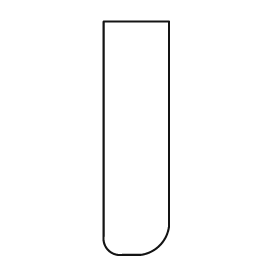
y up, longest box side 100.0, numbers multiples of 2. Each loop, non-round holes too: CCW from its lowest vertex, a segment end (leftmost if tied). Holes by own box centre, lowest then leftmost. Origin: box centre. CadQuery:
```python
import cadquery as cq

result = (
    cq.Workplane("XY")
    .moveTo(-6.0, -50.0)
    .lineTo(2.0, -50.0)
    .threePointArc((10.0, -46.0), (14.0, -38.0))
    .lineTo(14.0, 50.0)
    .lineTo(-14.0, 50.0)
    .lineTo(-14.0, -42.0)
    .threePointArc((-12.0, -48.0), (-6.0, -50.0))
    .close()
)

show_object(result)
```